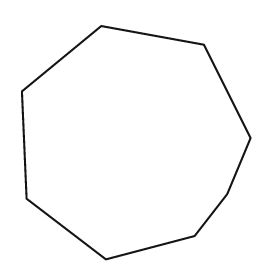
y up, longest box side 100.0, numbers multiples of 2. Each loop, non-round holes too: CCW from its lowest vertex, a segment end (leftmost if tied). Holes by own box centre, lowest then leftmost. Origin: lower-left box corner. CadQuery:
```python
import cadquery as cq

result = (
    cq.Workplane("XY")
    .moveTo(36.0, 0.0)
    .lineTo(74.0, 10.0)
    .lineTo(88.0, 28.0)
    .lineTo(98.0, 52.0)
    .lineTo(78.0, 92.0)
    .lineTo(34.0, 100.0)
    .lineTo(0.0, 72.0)
    .lineTo(2.0, 26.0)
    .close()
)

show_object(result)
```